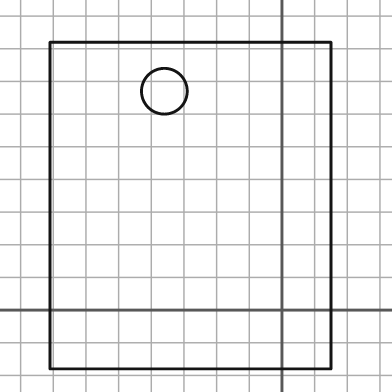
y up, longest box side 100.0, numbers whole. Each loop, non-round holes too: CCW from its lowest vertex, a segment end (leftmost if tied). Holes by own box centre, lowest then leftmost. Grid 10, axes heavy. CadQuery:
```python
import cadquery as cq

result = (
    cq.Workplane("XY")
    .moveTo(-71.0, -18.0)
    .lineTo(15.0, -18.0)
    .lineTo(15.0, 82.0)
    .lineTo(-71.0, 82.0)
    .close()
    .moveTo(-36.0, 67.0)
    .circle(7.0)
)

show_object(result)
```